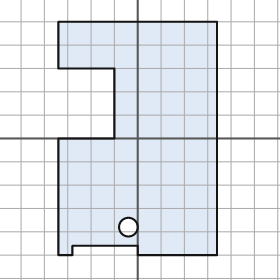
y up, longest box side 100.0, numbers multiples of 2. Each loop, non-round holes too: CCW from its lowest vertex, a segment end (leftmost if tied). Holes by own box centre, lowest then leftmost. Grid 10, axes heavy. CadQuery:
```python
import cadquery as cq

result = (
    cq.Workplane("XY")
    .moveTo(-34.0, -50.0)
    .lineTo(-28.0, -50.0)
    .lineTo(-28.0, -46.0)
    .lineTo(0.0, -46.0)
    .lineTo(0.0, -50.0)
    .lineTo(34.0, -50.0)
    .lineTo(34.0, 50.0)
    .lineTo(-34.0, 50.0)
    .lineTo(-34.0, 30.0)
    .lineTo(-10.0, 30.0)
    .lineTo(-10.0, 0.0)
    .lineTo(-34.0, 0.0)
    .close()
    .moveTo(-4.0, -38.0)
    .circle(4.0)
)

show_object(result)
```